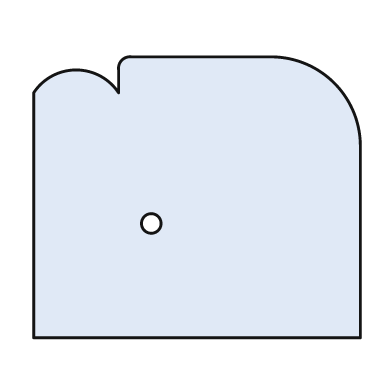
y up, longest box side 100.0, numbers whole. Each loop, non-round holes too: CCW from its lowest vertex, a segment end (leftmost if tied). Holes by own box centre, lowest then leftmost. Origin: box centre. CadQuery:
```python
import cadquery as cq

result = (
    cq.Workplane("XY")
    .moveTo(-50.0, -43.0)
    .lineTo(50.0, -43.0)
    .lineTo(50.0, 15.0)
    .threePointArc((42.0, 35.0), (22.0, 43.0))
    .lineTo(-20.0, 43.0)
    .threePointArc((-23.0, 42.0), (-24.0, 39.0))
    .lineTo(-24.0, 32.0)
    .threePointArc((-37.0, 39.0), (-50.0, 32.0))
    .close()
    .moveTo(-14.0, -8.0)
    .circle(3.0)
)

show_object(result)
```